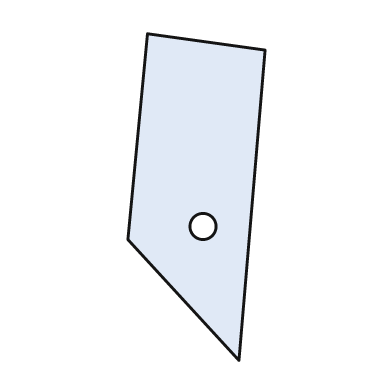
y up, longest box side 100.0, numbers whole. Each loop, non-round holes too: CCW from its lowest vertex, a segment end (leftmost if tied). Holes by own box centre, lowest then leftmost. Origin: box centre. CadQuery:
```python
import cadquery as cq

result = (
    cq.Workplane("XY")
    .moveTo(13.0, -50.0)
    .lineTo(21.0, 45.0)
    .lineTo(-15.0, 50.0)
    .lineTo(-21.0, -13.0)
    .close()
    .moveTo(2.0, -9.0)
    .circle(4.0)
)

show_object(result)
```